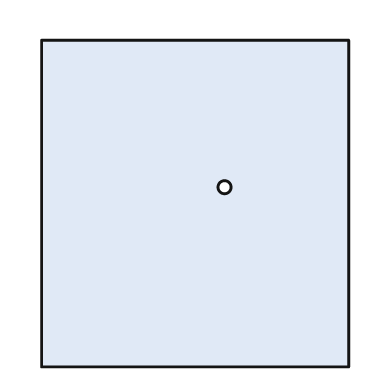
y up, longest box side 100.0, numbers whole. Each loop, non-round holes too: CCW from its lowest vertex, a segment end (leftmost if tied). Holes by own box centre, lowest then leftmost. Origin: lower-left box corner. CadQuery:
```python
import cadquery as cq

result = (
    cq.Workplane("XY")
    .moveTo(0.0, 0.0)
    .lineTo(94.0, 0.0)
    .lineTo(94.0, 100.0)
    .lineTo(0.0, 100.0)
    .close()
    .moveTo(56.0, 55.0)
    .circle(2.0)
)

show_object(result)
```